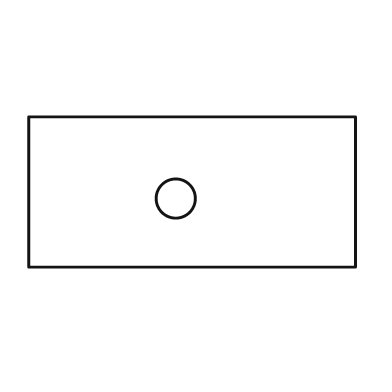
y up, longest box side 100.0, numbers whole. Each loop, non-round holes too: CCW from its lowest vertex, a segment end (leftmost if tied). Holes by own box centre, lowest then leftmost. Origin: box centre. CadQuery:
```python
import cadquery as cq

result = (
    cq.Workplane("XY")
    .moveTo(-50.0, -23.0)
    .lineTo(50.0, -23.0)
    .lineTo(50.0, 23.0)
    .lineTo(-50.0, 23.0)
    .close()
    .moveTo(-5.0, -2.0)
    .circle(6.0)
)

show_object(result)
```